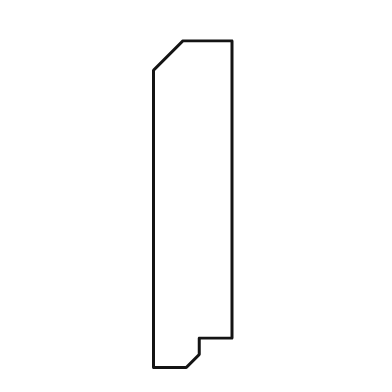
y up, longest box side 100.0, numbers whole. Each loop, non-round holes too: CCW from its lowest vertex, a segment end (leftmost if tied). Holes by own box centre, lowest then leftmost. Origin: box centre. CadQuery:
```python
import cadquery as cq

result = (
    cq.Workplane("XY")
    .moveTo(-12.0, -50.0)
    .lineTo(-2.0, -50.0)
    .lineTo(2.0, -46.0)
    .lineTo(2.0, -41.0)
    .lineTo(12.0, -41.0)
    .lineTo(12.0, 50.0)
    .lineTo(-3.0, 50.0)
    .lineTo(-12.0, 41.0)
    .close()
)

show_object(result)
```